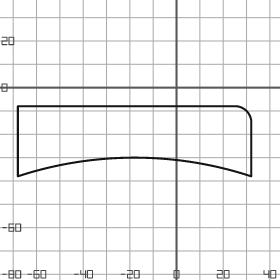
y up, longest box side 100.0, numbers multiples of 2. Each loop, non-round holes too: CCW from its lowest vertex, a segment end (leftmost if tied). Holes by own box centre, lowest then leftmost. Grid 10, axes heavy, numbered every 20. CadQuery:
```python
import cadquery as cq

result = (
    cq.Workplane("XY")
    .moveTo(-68.0, -38.0)
    .threePointArc((-18.0, -30.0), (32.0, -38.0))
    .lineTo(32.0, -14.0)
    .threePointArc((30.0, -10.0), (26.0, -8.0))
    .lineTo(-68.0, -8.0)
    .close()
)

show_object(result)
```